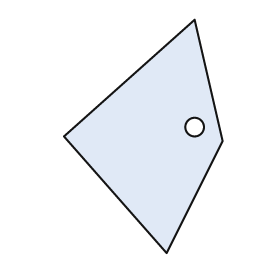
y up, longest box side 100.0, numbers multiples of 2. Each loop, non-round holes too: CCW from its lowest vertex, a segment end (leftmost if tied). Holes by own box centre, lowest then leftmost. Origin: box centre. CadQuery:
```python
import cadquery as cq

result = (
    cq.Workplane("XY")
    .moveTo(10.0, -50.0)
    .lineTo(34.0, -2.0)
    .lineTo(22.0, 50.0)
    .lineTo(-34.0, 0.0)
    .close()
    .moveTo(22.0, 4.0)
    .circle(4.0)
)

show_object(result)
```